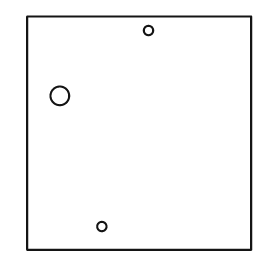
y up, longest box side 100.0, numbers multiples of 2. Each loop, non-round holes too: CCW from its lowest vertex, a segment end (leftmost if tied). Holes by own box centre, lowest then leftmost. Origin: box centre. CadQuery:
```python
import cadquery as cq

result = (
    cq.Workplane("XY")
    .moveTo(-48.0, -50.0)
    .lineTo(48.0, -50.0)
    .lineTo(48.0, 50.0)
    .lineTo(-48.0, 50.0)
    .close()
    .moveTo(-16.0, -40.0)
    .circle(2.0)
    .moveTo(-34.0, 16.0)
    .circle(4.0)
    .moveTo(4.0, 44.0)
    .circle(2.0)
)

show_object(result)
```